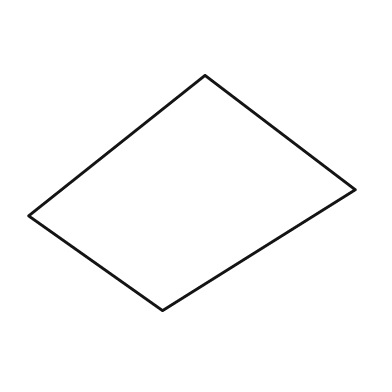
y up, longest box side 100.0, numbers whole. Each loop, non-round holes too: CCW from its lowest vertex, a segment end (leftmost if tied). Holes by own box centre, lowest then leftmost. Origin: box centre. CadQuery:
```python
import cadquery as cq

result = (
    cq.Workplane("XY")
    .moveTo(-9.0, -36.0)
    .lineTo(50.0, 1.0)
    .lineTo(4.0, 36.0)
    .lineTo(-50.0, -7.0)
    .close()
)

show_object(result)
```